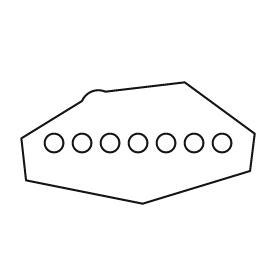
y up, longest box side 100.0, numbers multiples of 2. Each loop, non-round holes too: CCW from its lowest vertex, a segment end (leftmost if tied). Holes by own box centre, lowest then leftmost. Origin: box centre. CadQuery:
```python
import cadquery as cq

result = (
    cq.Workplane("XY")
    .moveTo(2.0, -26.0)
    .lineTo(48.0, -12.0)
    .lineTo(50.0, 4.0)
    .lineTo(20.0, 26.0)
    .lineTo(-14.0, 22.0)
    .threePointArc((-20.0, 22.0), (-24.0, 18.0))
    .lineTo(-50.0, 2.0)
    .lineTo(-48.0, -16.0)
    .close()
    .moveTo(-36.0, 0.0)
    .circle(4.0)
    .moveTo(-24.0, 0.0)
    .circle(4.0)
    .moveTo(-12.0, 0.0)
    .circle(4.0)
    .moveTo(0.0, 0.0)
    .circle(4.0)
    .moveTo(12.0, 0.0)
    .circle(4.0)
    .moveTo(24.0, 0.0)
    .circle(4.0)
    .moveTo(36.0, 0.0)
    .circle(4.0)
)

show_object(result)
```